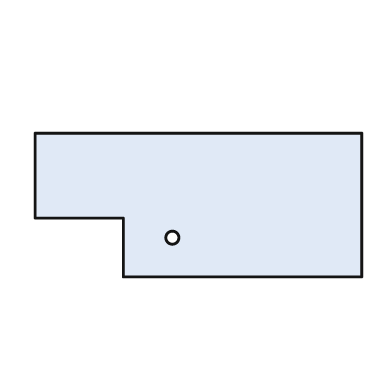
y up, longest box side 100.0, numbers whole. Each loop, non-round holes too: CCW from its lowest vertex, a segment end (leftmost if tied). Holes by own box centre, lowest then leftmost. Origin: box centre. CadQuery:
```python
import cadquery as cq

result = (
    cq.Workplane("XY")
    .moveTo(-23.0, -22.0)
    .lineTo(50.0, -22.0)
    .lineTo(50.0, 22.0)
    .lineTo(-50.0, 22.0)
    .lineTo(-50.0, -4.0)
    .lineTo(-23.0, -4.0)
    .close()
    .moveTo(-8.0, -10.0)
    .circle(2.0)
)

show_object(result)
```